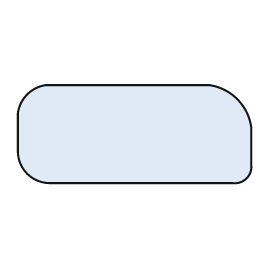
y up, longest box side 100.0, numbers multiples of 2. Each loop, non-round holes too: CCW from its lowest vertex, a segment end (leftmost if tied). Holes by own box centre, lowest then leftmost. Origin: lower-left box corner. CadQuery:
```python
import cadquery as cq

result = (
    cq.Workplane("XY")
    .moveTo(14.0, 0.0)
    .lineTo(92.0, 0.0)
    .threePointArc((98.0, 2.0), (100.0, 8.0))
    .lineTo(100.0, 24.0)
    .threePointArc((94.0, 36.0), (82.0, 42.0))
    .lineTo(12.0, 42.0)
    .threePointArc((4.0, 38.0), (0.0, 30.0))
    .lineTo(0.0, 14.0)
    .threePointArc((4.0, 4.0), (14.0, 0.0))
    .close()
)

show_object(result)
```